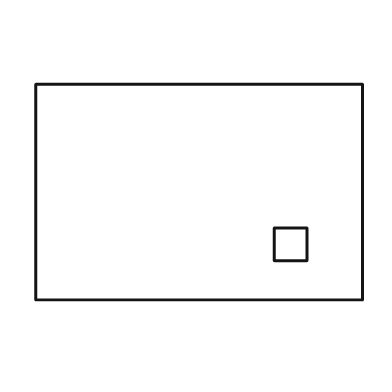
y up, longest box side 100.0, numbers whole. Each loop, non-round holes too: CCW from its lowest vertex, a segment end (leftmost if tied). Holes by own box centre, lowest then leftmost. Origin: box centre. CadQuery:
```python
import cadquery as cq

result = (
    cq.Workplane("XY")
    .moveTo(-50.0, -33.0)
    .lineTo(50.0, -33.0)
    .lineTo(50.0, 33.0)
    .lineTo(-50.0, 33.0)
    .close()
    .moveTo(23.0, -21.0)
    .lineTo(33.0, -21.0)
    .lineTo(33.0, -11.0)
    .lineTo(23.0, -11.0)
    .close()
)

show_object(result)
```